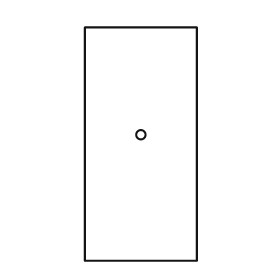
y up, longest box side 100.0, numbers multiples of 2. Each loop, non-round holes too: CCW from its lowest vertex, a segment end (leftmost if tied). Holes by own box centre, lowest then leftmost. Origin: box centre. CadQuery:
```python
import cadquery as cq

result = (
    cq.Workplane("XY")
    .moveTo(-24.0, -50.0)
    .lineTo(24.0, -50.0)
    .lineTo(24.0, 50.0)
    .lineTo(-24.0, 50.0)
    .close()
    .moveTo(0.0, 4.0)
    .circle(2.0)
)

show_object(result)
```